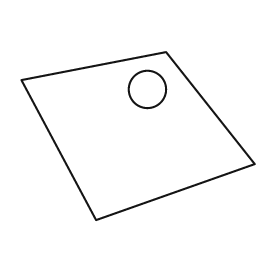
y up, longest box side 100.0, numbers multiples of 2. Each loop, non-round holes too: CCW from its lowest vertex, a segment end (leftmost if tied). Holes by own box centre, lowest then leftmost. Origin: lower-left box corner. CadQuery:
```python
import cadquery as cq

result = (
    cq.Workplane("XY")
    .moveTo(32.0, 0.0)
    .lineTo(100.0, 24.0)
    .lineTo(62.0, 72.0)
    .lineTo(0.0, 60.0)
    .close()
    .moveTo(54.0, 56.0)
    .circle(8.0)
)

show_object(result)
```